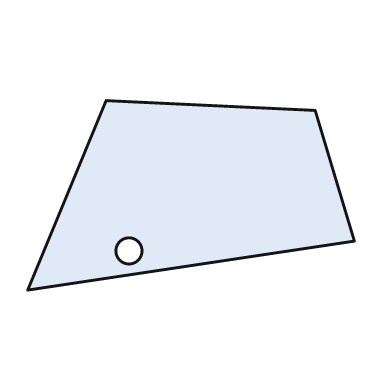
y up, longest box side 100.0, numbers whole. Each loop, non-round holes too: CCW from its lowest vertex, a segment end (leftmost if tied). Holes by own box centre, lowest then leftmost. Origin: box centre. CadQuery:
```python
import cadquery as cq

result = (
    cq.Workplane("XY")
    .moveTo(-50.0, -29.0)
    .lineTo(50.0, -14.0)
    .lineTo(38.0, 26.0)
    .lineTo(-26.0, 29.0)
    .close()
    .moveTo(-19.0, -17.0)
    .circle(4.0)
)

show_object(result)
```